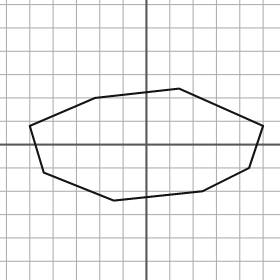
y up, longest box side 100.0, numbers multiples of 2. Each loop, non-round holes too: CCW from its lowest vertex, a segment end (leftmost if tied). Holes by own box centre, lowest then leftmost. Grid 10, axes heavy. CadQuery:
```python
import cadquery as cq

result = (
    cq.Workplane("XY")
    .moveTo(-14.0, -24.0)
    .lineTo(24.0, -20.0)
    .lineTo(44.0, -10.0)
    .lineTo(50.0, 8.0)
    .lineTo(14.0, 24.0)
    .lineTo(-22.0, 20.0)
    .lineTo(-50.0, 8.0)
    .lineTo(-44.0, -12.0)
    .close()
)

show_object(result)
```